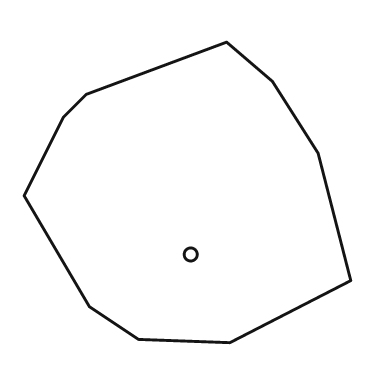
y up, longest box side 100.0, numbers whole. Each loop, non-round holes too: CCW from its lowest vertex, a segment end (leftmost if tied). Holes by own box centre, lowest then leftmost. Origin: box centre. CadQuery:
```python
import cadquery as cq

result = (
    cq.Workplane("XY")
    .moveTo(13.0, -46.0)
    .lineTo(50.0, -27.0)
    .lineTo(40.0, 12.0)
    .lineTo(26.0, 34.0)
    .lineTo(12.0, 46.0)
    .lineTo(-31.0, 30.0)
    .lineTo(-38.0, 23.0)
    .lineTo(-50.0, -1.0)
    .lineTo(-30.0, -35.0)
    .lineTo(-15.0, -45.0)
    .close()
    .moveTo(1.0, -19.0)
    .circle(2.0)
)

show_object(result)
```